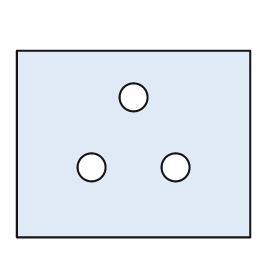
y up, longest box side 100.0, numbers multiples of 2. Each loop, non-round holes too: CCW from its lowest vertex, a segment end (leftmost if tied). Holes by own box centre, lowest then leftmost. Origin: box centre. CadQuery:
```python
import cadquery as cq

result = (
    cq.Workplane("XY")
    .moveTo(-50.0, -40.0)
    .lineTo(50.0, -40.0)
    .lineTo(50.0, 40.0)
    .lineTo(-50.0, 40.0)
    .close()
    .moveTo(-18.0, -10.0)
    .circle(6.0)
    .moveTo(18.0, -10.0)
    .circle(6.0)
    .moveTo(0.0, 20.0)
    .circle(6.0)
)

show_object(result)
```